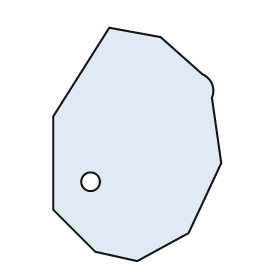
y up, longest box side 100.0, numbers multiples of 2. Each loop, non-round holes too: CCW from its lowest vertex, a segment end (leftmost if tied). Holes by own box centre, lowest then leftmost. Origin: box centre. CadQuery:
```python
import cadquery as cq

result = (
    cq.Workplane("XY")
    .moveTo(0.0, -50.0)
    .lineTo(22.0, -38.0)
    .lineTo(36.0, -8.0)
    .lineTo(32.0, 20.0)
    .threePointArc((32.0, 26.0), (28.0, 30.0))
    .lineTo(10.0, 46.0)
    .lineTo(-12.0, 50.0)
    .lineTo(-36.0, 12.0)
    .lineTo(-36.0, -28.0)
    .lineTo(-18.0, -46.0)
    .close()
    .moveTo(-20.0, -16.0)
    .circle(4.0)
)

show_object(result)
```